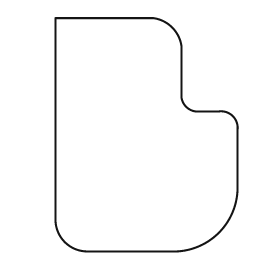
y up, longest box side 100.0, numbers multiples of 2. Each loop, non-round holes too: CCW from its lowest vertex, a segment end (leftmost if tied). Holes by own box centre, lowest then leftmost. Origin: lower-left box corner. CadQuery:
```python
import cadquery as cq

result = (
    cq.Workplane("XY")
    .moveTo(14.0, 0.0)
    .lineTo(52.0, 0.0)
    .threePointArc((70.0, 8.0), (78.0, 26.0))
    .lineTo(78.0, 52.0)
    .threePointArc((76.0, 58.0), (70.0, 60.0))
    .lineTo(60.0, 60.0)
    .threePointArc((56.0, 62.0), (54.0, 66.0))
    .lineTo(54.0, 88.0)
    .threePointArc((50.0, 96.0), (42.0, 100.0))
    .lineTo(0.0, 100.0)
    .lineTo(0.0, 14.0)
    .threePointArc((4.0, 4.0), (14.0, 0.0))
    .close()
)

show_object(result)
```